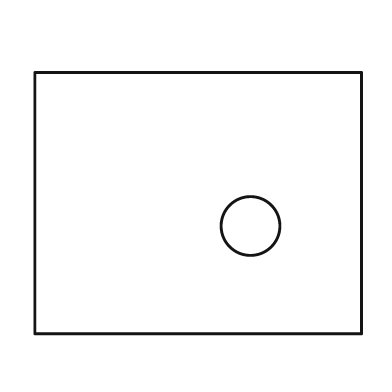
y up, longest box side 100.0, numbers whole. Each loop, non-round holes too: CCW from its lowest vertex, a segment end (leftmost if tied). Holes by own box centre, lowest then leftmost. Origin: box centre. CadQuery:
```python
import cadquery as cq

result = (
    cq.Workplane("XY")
    .moveTo(-50.0, -40.0)
    .lineTo(50.0, -40.0)
    .lineTo(50.0, 40.0)
    .lineTo(-50.0, 40.0)
    .close()
    .moveTo(16.0, -7.0)
    .circle(9.0)
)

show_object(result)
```